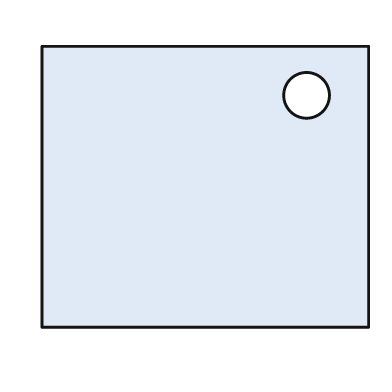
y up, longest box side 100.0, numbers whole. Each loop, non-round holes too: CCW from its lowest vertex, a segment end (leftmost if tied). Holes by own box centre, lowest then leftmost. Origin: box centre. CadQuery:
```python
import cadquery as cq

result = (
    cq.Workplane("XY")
    .moveTo(-50.0, -43.0)
    .lineTo(50.0, -43.0)
    .lineTo(50.0, 43.0)
    .lineTo(-50.0, 43.0)
    .close()
    .moveTo(31.0, 28.0)
    .circle(7.0)
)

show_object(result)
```